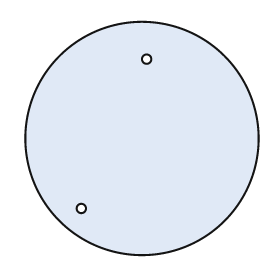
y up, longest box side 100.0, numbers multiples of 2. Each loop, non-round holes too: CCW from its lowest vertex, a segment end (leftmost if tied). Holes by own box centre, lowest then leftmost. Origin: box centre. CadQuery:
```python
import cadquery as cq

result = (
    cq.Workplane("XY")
    .moveTo(0.0, 0.0)
    .circle(50.0)
    .moveTo(-26.0, -30.0)
    .circle(2.0)
    .moveTo(2.0, 34.0)
    .circle(2.0)
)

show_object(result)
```